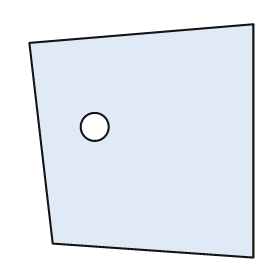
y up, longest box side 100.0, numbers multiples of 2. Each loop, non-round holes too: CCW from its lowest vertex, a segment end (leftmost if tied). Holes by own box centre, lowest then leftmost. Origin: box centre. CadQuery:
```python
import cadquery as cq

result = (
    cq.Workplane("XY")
    .moveTo(48.0, -50.0)
    .lineTo(48.0, 50.0)
    .lineTo(-48.0, 42.0)
    .lineTo(-38.0, -44.0)
    .close()
    .moveTo(-20.0, 6.0)
    .circle(6.0)
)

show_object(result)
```